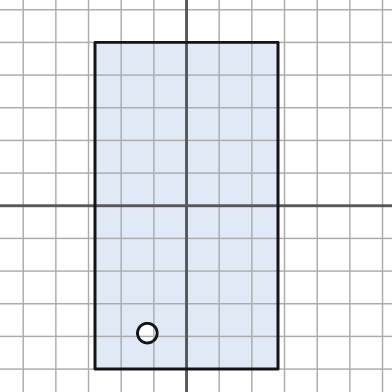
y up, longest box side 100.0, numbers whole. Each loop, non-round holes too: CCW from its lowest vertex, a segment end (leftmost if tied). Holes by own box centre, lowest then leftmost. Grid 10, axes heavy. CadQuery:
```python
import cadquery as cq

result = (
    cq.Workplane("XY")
    .moveTo(-28.0, -50.0)
    .lineTo(28.0, -50.0)
    .lineTo(28.0, 50.0)
    .lineTo(-28.0, 50.0)
    .close()
    .moveTo(-12.0, -39.0)
    .circle(3.0)
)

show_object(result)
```